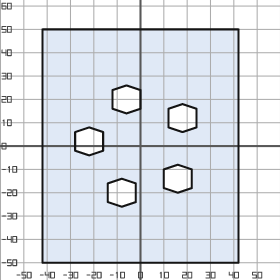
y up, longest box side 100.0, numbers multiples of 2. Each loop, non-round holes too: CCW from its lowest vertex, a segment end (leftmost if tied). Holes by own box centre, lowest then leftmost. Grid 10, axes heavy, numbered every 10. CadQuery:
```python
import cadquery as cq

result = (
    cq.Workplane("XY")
    .moveTo(-42.0, -50.0)
    .lineTo(42.0, -50.0)
    .lineTo(42.0, 50.0)
    .lineTo(-42.0, 50.0)
    .close()
    .moveTo(-8.0, -26.0)
    .lineTo(-2.0, -24.0)
    .lineTo(-2.0, -16.0)
    .lineTo(-8.0, -14.0)
    .lineTo(-14.0, -16.0)
    .lineTo(-14.0, -24.0)
    .close()
    .moveTo(16.0, -20.0)
    .lineTo(22.0, -18.0)
    .lineTo(22.0, -10.0)
    .lineTo(16.0, -8.0)
    .lineTo(10.0, -10.0)
    .lineTo(10.0, -18.0)
    .close()
    .moveTo(-22.0, -4.0)
    .lineTo(-16.0, -2.0)
    .lineTo(-16.0, 6.0)
    .lineTo(-22.0, 8.0)
    .lineTo(-28.0, 6.0)
    .lineTo(-28.0, -2.0)
    .close()
    .moveTo(18.0, 6.0)
    .lineTo(24.0, 8.0)
    .lineTo(24.0, 16.0)
    .lineTo(18.0, 18.0)
    .lineTo(12.0, 16.0)
    .lineTo(12.0, 8.0)
    .close()
    .moveTo(-6.0, 14.0)
    .lineTo(0.0, 16.0)
    .lineTo(0.0, 24.0)
    .lineTo(-6.0, 26.0)
    .lineTo(-12.0, 24.0)
    .lineTo(-12.0, 16.0)
    .close()
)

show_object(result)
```